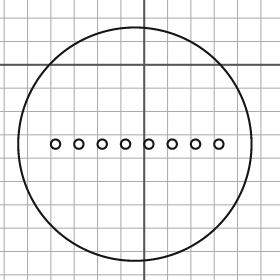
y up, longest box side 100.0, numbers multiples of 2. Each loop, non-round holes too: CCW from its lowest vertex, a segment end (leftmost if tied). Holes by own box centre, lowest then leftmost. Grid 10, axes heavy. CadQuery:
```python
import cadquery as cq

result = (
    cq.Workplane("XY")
    .moveTo(-4.0, -34.0)
    .circle(50.0)
    .moveTo(-38.0, -34.0)
    .circle(2.0)
    .moveTo(-28.0, -34.0)
    .circle(2.0)
    .moveTo(-18.0, -34.0)
    .circle(2.0)
    .moveTo(-8.0, -34.0)
    .circle(2.0)
    .moveTo(2.0, -34.0)
    .circle(2.0)
    .moveTo(12.0, -34.0)
    .circle(2.0)
    .moveTo(22.0, -34.0)
    .circle(2.0)
    .moveTo(32.0, -34.0)
    .circle(2.0)
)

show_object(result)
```